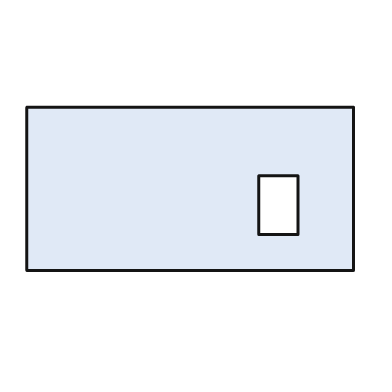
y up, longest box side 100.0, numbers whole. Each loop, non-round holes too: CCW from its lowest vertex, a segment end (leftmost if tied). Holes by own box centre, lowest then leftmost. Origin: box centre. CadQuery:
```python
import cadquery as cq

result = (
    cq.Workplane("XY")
    .moveTo(-50.0, -25.0)
    .lineTo(50.0, -25.0)
    .lineTo(50.0, 25.0)
    .lineTo(-50.0, 25.0)
    .close()
    .moveTo(21.0, -14.0)
    .lineTo(33.0, -14.0)
    .lineTo(33.0, 4.0)
    .lineTo(21.0, 4.0)
    .close()
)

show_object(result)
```